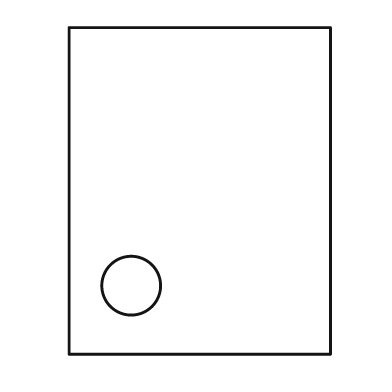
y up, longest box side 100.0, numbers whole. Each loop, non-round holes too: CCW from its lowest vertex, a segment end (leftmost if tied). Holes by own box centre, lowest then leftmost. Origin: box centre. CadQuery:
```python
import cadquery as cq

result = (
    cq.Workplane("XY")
    .moveTo(-40.0, -50.0)
    .lineTo(40.0, -50.0)
    .lineTo(40.0, 50.0)
    .lineTo(-40.0, 50.0)
    .close()
    .moveTo(-21.0, -29.0)
    .circle(9.0)
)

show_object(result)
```